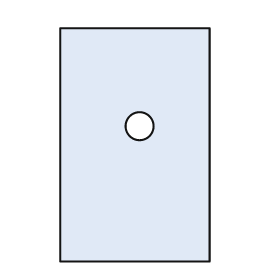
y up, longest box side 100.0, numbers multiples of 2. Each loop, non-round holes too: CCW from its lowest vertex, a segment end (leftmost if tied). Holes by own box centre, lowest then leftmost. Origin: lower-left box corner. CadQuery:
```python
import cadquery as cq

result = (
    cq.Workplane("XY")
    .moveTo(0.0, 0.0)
    .lineTo(64.0, 0.0)
    .lineTo(64.0, 100.0)
    .lineTo(0.0, 100.0)
    .close()
    .moveTo(34.0, 58.0)
    .circle(6.0)
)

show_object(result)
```